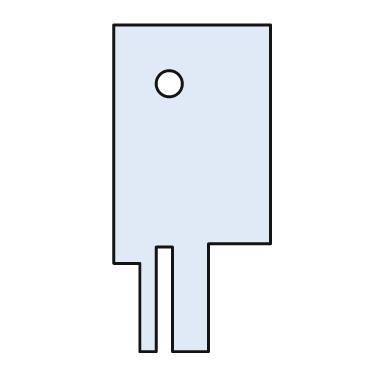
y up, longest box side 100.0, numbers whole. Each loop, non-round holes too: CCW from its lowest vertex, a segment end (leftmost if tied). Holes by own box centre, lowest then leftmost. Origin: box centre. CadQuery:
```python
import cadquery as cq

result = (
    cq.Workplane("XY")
    .moveTo(-16.0, -50.0)
    .lineTo(-11.0, -50.0)
    .lineTo(-11.0, -18.0)
    .lineTo(-6.0, -18.0)
    .lineTo(-6.0, -50.0)
    .lineTo(5.0, -50.0)
    .lineTo(5.0, -17.0)
    .lineTo(24.0, -17.0)
    .lineTo(24.0, 50.0)
    .lineTo(-24.0, 50.0)
    .lineTo(-24.0, -23.0)
    .lineTo(-16.0, -23.0)
    .close()
    .moveTo(-7.0, 32.0)
    .circle(4.0)
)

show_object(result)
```